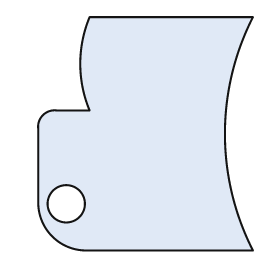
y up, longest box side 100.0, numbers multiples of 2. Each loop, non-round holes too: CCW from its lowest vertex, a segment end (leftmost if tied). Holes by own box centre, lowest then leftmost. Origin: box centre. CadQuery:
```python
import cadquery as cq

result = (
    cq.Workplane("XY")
    .moveTo(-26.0, -50.0)
    .lineTo(46.0, -50.0)
    .threePointArc((34.0, 0.0), (46.0, 50.0))
    .lineTo(-24.0, 50.0)
    .threePointArc((-28.0, 30.0), (-24.0, 10.0))
    .lineTo(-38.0, 10.0)
    .threePointArc((-44.0, 8.0), (-46.0, 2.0))
    .lineTo(-46.0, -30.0)
    .threePointArc((-40.0, -44.0), (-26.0, -50.0))
    .close()
    .moveTo(-34.0, -30.0)
    .circle(8.0)
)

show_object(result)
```